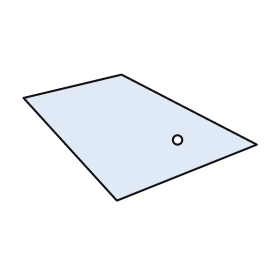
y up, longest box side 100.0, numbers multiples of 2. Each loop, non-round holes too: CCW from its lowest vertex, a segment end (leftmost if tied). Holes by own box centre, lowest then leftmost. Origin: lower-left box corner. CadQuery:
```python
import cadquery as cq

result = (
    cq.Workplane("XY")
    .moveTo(40.0, 0.0)
    .lineTo(100.0, 24.0)
    .lineTo(42.0, 54.0)
    .lineTo(0.0, 44.0)
    .close()
    .moveTo(66.0, 26.0)
    .circle(2.0)
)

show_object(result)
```